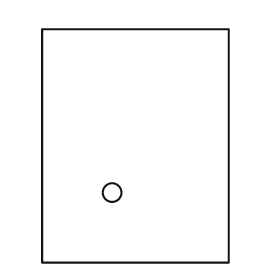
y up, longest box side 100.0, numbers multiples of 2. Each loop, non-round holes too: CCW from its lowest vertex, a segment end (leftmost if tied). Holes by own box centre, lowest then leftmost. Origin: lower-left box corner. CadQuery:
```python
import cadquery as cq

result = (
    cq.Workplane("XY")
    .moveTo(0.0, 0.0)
    .lineTo(80.0, 0.0)
    .lineTo(80.0, 100.0)
    .lineTo(0.0, 100.0)
    .close()
    .moveTo(30.0, 30.0)
    .circle(4.0)
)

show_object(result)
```